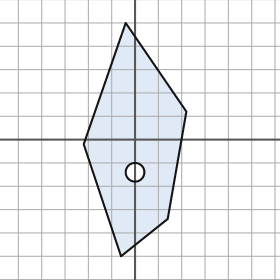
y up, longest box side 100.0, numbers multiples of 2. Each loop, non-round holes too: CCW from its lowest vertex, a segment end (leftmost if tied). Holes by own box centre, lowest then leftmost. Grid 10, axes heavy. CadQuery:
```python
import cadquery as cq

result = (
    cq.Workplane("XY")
    .moveTo(-6.0, -50.0)
    .lineTo(14.0, -34.0)
    .lineTo(22.0, 12.0)
    .lineTo(-4.0, 50.0)
    .lineTo(-22.0, -2.0)
    .close()
    .moveTo(0.0, -14.0)
    .circle(4.0)
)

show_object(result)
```